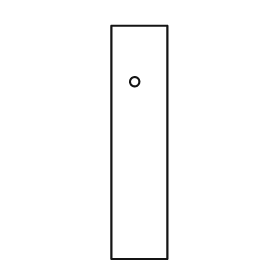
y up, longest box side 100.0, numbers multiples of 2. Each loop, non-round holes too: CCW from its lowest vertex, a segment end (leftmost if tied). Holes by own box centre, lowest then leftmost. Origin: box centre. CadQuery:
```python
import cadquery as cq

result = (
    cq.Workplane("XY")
    .moveTo(-12.0, -50.0)
    .lineTo(12.0, -50.0)
    .lineTo(12.0, 50.0)
    .lineTo(-12.0, 50.0)
    .close()
    .moveTo(-2.0, 26.0)
    .circle(2.0)
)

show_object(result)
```